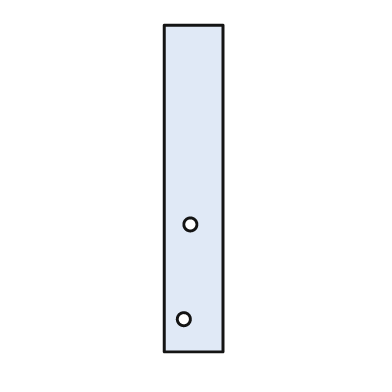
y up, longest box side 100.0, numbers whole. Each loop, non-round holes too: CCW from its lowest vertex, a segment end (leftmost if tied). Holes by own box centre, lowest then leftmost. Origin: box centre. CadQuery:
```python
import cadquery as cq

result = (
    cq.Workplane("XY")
    .moveTo(-9.0, -50.0)
    .lineTo(9.0, -50.0)
    .lineTo(9.0, 50.0)
    .lineTo(-9.0, 50.0)
    .close()
    .moveTo(-3.0, -40.0)
    .circle(2.0)
    .moveTo(-1.0, -11.0)
    .circle(2.0)
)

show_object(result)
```